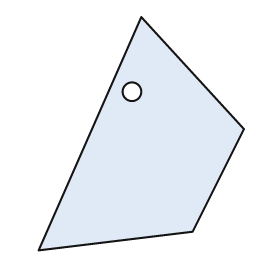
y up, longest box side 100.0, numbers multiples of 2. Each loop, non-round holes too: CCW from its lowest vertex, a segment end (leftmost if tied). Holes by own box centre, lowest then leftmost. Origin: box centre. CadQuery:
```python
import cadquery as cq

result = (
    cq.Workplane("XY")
    .moveTo(-44.0, -50.0)
    .lineTo(22.0, -42.0)
    .lineTo(44.0, 2.0)
    .lineTo(0.0, 50.0)
    .close()
    .moveTo(-4.0, 18.0)
    .circle(4.0)
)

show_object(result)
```